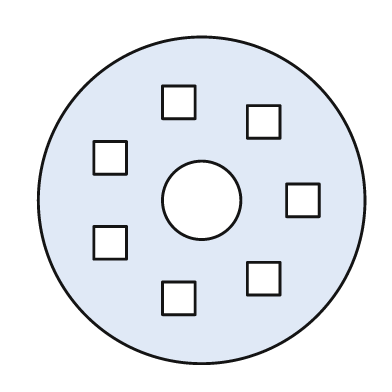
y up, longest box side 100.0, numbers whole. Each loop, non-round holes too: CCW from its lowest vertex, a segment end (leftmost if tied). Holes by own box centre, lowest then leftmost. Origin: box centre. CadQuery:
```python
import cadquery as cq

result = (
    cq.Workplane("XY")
    .moveTo(0.0, 0.0)
    .circle(50.0)
    .moveTo(-12.0, -35.0)
    .lineTo(-2.0, -35.0)
    .lineTo(-2.0, -25.0)
    .lineTo(-12.0, -25.0)
    .close()
    .moveTo(14.0, -29.0)
    .lineTo(24.0, -29.0)
    .lineTo(24.0, -19.0)
    .lineTo(14.0, -19.0)
    .close()
    .moveTo(-33.0, -18.0)
    .lineTo(-23.0, -18.0)
    .lineTo(-23.0, -8.0)
    .lineTo(-33.0, -8.0)
    .close()
    .moveTo(0.0, 0.0)
    .circle(12.0)
    .moveTo(26.0, -5.0)
    .lineTo(36.0, -5.0)
    .lineTo(36.0, 5.0)
    .lineTo(26.0, 5.0)
    .close()
    .moveTo(-33.0, 8.0)
    .lineTo(-23.0, 8.0)
    .lineTo(-23.0, 18.0)
    .lineTo(-33.0, 18.0)
    .close()
    .moveTo(14.0, 19.0)
    .lineTo(24.0, 19.0)
    .lineTo(24.0, 29.0)
    .lineTo(14.0, 29.0)
    .close()
    .moveTo(-12.0, 25.0)
    .lineTo(-2.0, 25.0)
    .lineTo(-2.0, 35.0)
    .lineTo(-12.0, 35.0)
    .close()
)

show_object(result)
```